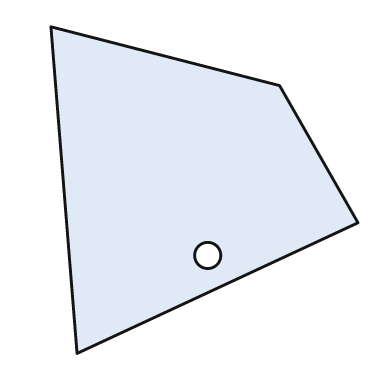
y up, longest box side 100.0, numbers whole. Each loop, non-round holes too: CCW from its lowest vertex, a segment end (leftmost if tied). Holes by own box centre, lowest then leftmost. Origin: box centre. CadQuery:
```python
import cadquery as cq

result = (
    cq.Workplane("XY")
    .moveTo(-39.0, -50.0)
    .lineTo(47.0, -10.0)
    .lineTo(23.0, 32.0)
    .lineTo(-47.0, 50.0)
    .close()
    .moveTo(1.0, -20.0)
    .circle(4.0)
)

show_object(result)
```